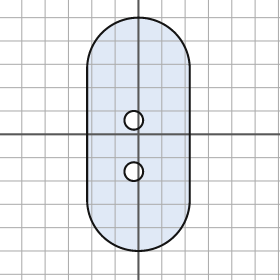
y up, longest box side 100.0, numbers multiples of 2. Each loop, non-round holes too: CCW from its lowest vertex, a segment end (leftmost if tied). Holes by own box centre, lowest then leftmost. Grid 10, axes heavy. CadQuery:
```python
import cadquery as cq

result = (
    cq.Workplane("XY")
    .moveTo(-22.0, -28.0)
    .threePointArc((0.0, -50.0), (22.0, -28.0))
    .lineTo(22.0, 28.0)
    .threePointArc((0.0, 50.0), (-22.0, 28.0))
    .close()
    .moveTo(-2.0, -16.0)
    .circle(4.0)
    .moveTo(-2.0, 6.0)
    .circle(4.0)
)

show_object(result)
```